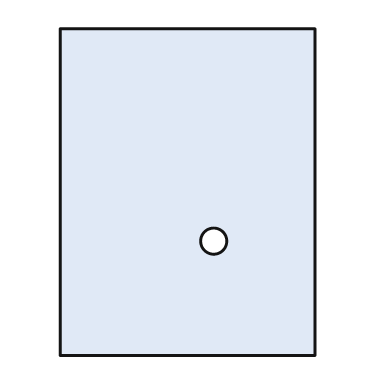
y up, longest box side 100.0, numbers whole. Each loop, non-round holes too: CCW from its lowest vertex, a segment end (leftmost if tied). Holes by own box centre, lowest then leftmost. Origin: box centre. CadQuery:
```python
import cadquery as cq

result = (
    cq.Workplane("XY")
    .moveTo(-39.0, -50.0)
    .lineTo(39.0, -50.0)
    .lineTo(39.0, 50.0)
    .lineTo(-39.0, 50.0)
    .close()
    .moveTo(8.0, -15.0)
    .circle(4.0)
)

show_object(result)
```